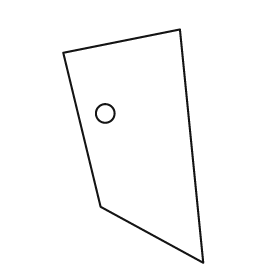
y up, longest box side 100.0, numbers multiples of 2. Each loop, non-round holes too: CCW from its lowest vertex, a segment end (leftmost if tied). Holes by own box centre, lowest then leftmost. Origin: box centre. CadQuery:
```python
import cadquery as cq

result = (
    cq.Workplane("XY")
    .moveTo(30.0, -50.0)
    .lineTo(20.0, 50.0)
    .lineTo(-30.0, 40.0)
    .lineTo(-14.0, -26.0)
    .close()
    .moveTo(-12.0, 14.0)
    .circle(4.0)
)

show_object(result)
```